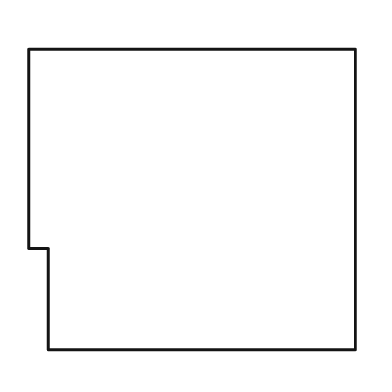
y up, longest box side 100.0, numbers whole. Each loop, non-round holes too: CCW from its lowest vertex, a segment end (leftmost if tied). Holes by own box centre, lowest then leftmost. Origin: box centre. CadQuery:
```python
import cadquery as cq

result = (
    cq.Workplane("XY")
    .moveTo(-44.0, -46.0)
    .lineTo(50.0, -46.0)
    .lineTo(50.0, 46.0)
    .lineTo(-50.0, 46.0)
    .lineTo(-50.0, -15.0)
    .lineTo(-44.0, -15.0)
    .close()
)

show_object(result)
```